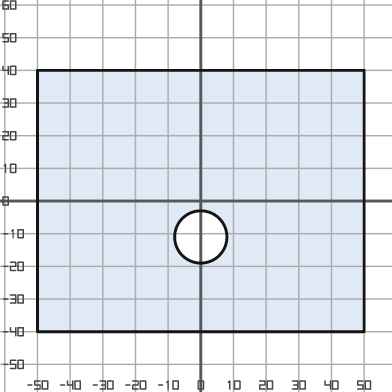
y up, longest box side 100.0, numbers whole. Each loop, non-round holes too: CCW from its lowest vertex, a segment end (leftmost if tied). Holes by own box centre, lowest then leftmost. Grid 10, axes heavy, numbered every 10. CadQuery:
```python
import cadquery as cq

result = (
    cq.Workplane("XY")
    .moveTo(-50.0, -40.0)
    .lineTo(50.0, -40.0)
    .lineTo(50.0, 40.0)
    .lineTo(-50.0, 40.0)
    .close()
    .moveTo(0.0, -11.0)
    .circle(8.0)
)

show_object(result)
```